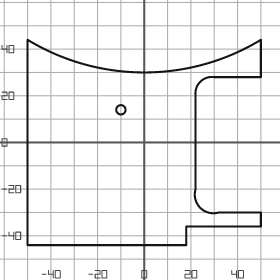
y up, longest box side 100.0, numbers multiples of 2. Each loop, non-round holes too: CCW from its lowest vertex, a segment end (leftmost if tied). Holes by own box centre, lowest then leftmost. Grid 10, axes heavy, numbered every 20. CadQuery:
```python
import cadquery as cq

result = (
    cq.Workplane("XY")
    .moveTo(-50.0, -44.0)
    .lineTo(18.0, -44.0)
    .lineTo(18.0, -36.0)
    .lineTo(50.0, -36.0)
    .lineTo(50.0, -30.0)
    .lineTo(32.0, -30.0)
    .threePointArc((24.0, -28.0), (22.0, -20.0))
    .lineTo(22.0, 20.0)
    .threePointArc((24.0, 26.0), (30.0, 28.0))
    .lineTo(50.0, 28.0)
    .lineTo(50.0, 44.0)
    .threePointArc((0.0, 30.0), (-50.0, 44.0))
    .close()
    .moveTo(-10.0, 14.0)
    .circle(2.0)
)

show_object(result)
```